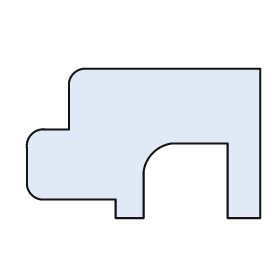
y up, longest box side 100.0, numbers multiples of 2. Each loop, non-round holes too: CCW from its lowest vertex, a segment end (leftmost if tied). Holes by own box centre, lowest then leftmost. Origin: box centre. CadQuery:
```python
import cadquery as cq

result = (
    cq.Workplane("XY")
    .moveTo(-12.0, -32.0)
    .lineTo(0.0, -32.0)
    .lineTo(0.0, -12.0)
    .threePointArc((4.0, -4.0), (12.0, 0.0))
    .lineTo(36.0, 0.0)
    .lineTo(36.0, -32.0)
    .lineTo(50.0, -32.0)
    .lineTo(50.0, 32.0)
    .lineTo(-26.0, 32.0)
    .threePointArc((-30.0, 30.0), (-32.0, 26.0))
    .lineTo(-32.0, 6.0)
    .lineTo(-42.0, 6.0)
    .threePointArc((-48.0, 4.0), (-50.0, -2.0))
    .lineTo(-50.0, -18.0)
    .threePointArc((-48.0, -22.0), (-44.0, -24.0))
    .lineTo(-12.0, -24.0)
    .close()
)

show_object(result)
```